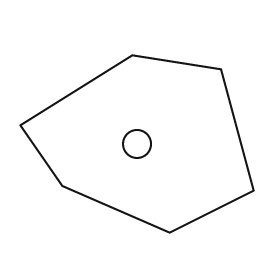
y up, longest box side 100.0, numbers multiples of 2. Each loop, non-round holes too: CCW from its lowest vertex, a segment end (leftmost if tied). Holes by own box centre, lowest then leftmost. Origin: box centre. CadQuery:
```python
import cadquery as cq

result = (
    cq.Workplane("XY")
    .moveTo(14.0, -38.0)
    .lineTo(50.0, -20.0)
    .lineTo(36.0, 32.0)
    .lineTo(-2.0, 38.0)
    .lineTo(-50.0, 8.0)
    .lineTo(-32.0, -18.0)
    .close()
    .moveTo(0.0, 0.0)
    .circle(6.0)
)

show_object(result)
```